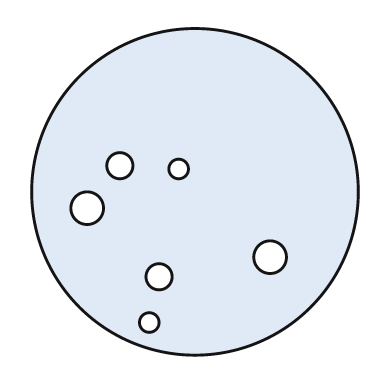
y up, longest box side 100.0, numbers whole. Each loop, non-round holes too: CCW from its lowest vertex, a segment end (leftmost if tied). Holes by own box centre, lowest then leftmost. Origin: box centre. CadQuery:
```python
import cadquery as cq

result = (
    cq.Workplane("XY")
    .moveTo(0.0, 0.0)
    .circle(50.0)
    .moveTo(-14.0, -40.0)
    .circle(3.0)
    .moveTo(-11.0, -26.0)
    .circle(4.0)
    .moveTo(23.0, -20.0)
    .circle(5.0)
    .moveTo(-33.0, -5.0)
    .circle(5.0)
    .moveTo(-5.0, 7.0)
    .circle(3.0)
    .moveTo(-23.0, 8.0)
    .circle(4.0)
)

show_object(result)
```